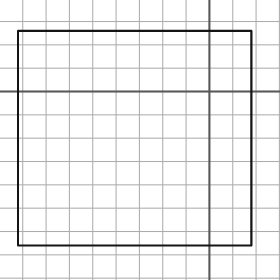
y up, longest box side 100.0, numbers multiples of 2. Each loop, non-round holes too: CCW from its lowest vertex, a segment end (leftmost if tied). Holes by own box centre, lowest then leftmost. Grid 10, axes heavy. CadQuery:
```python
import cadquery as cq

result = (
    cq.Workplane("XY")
    .moveTo(-82.0, -66.0)
    .lineTo(18.0, -66.0)
    .lineTo(18.0, 26.0)
    .lineTo(-82.0, 26.0)
    .close()
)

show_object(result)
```